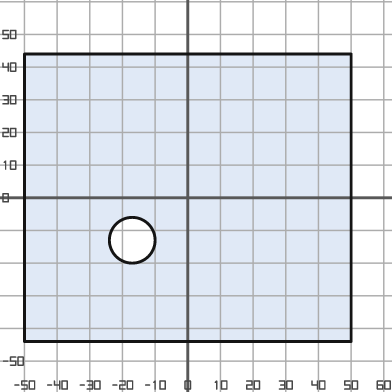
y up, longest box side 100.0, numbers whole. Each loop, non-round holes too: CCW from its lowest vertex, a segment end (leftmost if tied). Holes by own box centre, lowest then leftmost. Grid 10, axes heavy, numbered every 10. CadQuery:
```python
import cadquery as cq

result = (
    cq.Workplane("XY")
    .moveTo(-50.0, -44.0)
    .lineTo(50.0, -44.0)
    .lineTo(50.0, 44.0)
    .lineTo(-50.0, 44.0)
    .close()
    .moveTo(-17.0, -13.0)
    .circle(7.0)
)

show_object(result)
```